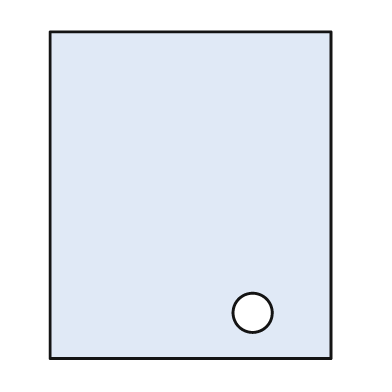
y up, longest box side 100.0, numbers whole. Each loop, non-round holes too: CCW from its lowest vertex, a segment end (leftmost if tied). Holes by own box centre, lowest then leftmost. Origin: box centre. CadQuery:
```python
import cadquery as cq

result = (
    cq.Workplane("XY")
    .moveTo(-43.0, -50.0)
    .lineTo(43.0, -50.0)
    .lineTo(43.0, 50.0)
    .lineTo(-43.0, 50.0)
    .close()
    .moveTo(19.0, -36.0)
    .circle(6.0)
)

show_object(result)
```